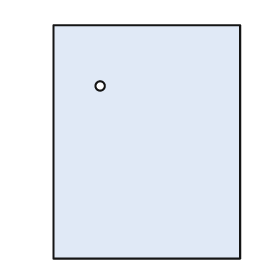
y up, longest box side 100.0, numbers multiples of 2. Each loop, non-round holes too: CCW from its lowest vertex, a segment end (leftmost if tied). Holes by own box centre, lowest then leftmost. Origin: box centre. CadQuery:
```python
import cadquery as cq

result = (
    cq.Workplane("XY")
    .moveTo(-40.0, -50.0)
    .lineTo(40.0, -50.0)
    .lineTo(40.0, 50.0)
    .lineTo(-40.0, 50.0)
    .close()
    .moveTo(-20.0, 24.0)
    .circle(2.0)
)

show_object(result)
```